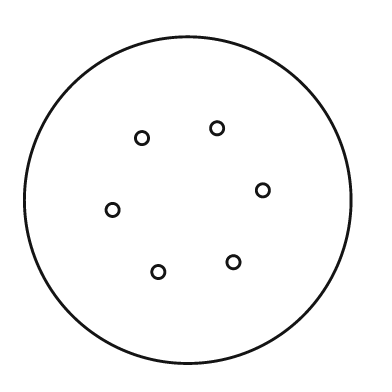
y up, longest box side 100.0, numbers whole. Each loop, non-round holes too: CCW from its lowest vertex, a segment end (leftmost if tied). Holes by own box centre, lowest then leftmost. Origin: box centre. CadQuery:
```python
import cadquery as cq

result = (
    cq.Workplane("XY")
    .moveTo(0.0, 0.0)
    .circle(50.0)
    .moveTo(-9.0, -22.0)
    .circle(2.0)
    .moveTo(14.0, -19.0)
    .circle(2.0)
    .moveTo(-23.0, -3.0)
    .circle(2.0)
    .moveTo(23.0, 3.0)
    .circle(2.0)
    .moveTo(-14.0, 19.0)
    .circle(2.0)
    .moveTo(9.0, 22.0)
    .circle(2.0)
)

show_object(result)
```